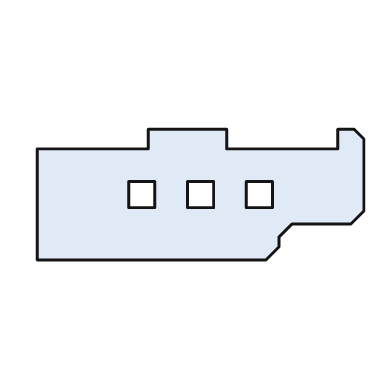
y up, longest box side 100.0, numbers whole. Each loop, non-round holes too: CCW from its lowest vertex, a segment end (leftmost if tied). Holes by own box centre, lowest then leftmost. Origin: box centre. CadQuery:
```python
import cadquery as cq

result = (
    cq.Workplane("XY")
    .moveTo(-50.0, -20.0)
    .lineTo(20.0, -20.0)
    .lineTo(24.0, -16.0)
    .lineTo(24.0, -13.0)
    .lineTo(28.0, -9.0)
    .lineTo(46.0, -9.0)
    .lineTo(50.0, -5.0)
    .lineTo(50.0, 17.0)
    .lineTo(47.0, 20.0)
    .lineTo(42.0, 20.0)
    .lineTo(42.0, 14.0)
    .lineTo(8.0, 14.0)
    .lineTo(8.0, 20.0)
    .lineTo(-16.0, 20.0)
    .lineTo(-16.0, 14.0)
    .lineTo(-50.0, 14.0)
    .close()
    .moveTo(-22.0, -4.0)
    .lineTo(-14.0, -4.0)
    .lineTo(-14.0, 4.0)
    .lineTo(-22.0, 4.0)
    .close()
    .moveTo(-4.0, -4.0)
    .lineTo(4.0, -4.0)
    .lineTo(4.0, 4.0)
    .lineTo(-4.0, 4.0)
    .close()
    .moveTo(14.0, -4.0)
    .lineTo(22.0, -4.0)
    .lineTo(22.0, 4.0)
    .lineTo(14.0, 4.0)
    .close()
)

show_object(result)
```